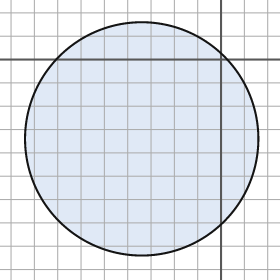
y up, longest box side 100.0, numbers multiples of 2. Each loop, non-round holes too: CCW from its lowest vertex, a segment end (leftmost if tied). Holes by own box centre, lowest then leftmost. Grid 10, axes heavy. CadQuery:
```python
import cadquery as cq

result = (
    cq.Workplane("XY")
    .moveTo(-34.0, -34.0)
    .circle(50.0)
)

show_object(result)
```